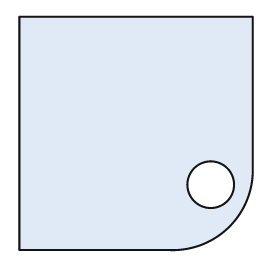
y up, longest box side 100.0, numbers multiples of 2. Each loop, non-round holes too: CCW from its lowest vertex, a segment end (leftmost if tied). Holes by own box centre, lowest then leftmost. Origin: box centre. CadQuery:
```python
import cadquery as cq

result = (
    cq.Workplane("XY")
    .moveTo(-50.0, -50.0)
    .lineTo(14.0, -50.0)
    .threePointArc((40.0, -40.0), (50.0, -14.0))
    .lineTo(50.0, 50.0)
    .lineTo(-50.0, 50.0)
    .close()
    .moveTo(32.0, -22.0)
    .circle(10.0)
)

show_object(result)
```